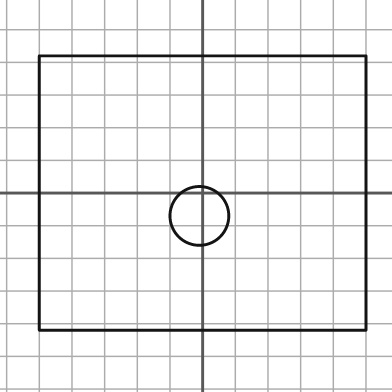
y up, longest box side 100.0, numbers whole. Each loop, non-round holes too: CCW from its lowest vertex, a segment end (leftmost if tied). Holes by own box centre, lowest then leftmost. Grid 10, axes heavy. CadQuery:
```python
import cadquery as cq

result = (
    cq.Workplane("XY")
    .moveTo(-50.0, -42.0)
    .lineTo(50.0, -42.0)
    .lineTo(50.0, 42.0)
    .lineTo(-50.0, 42.0)
    .close()
    .moveTo(-1.0, -7.0)
    .circle(9.0)
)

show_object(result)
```